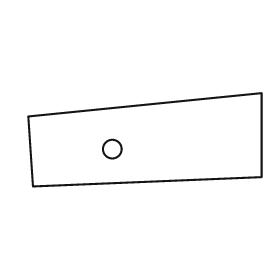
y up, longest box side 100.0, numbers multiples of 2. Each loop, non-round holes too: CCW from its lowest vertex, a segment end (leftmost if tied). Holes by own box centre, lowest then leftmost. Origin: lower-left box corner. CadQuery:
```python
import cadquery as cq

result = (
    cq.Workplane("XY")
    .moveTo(2.0, 0.0)
    .lineTo(100.0, 4.0)
    .lineTo(100.0, 40.0)
    .lineTo(0.0, 30.0)
    .close()
    .moveTo(36.0, 16.0)
    .circle(4.0)
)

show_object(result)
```